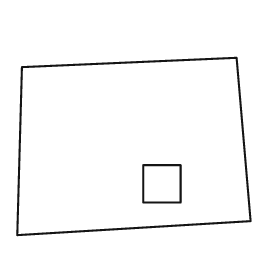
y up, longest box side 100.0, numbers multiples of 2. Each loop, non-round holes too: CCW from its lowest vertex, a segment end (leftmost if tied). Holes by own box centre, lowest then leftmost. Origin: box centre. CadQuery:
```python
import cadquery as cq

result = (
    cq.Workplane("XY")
    .moveTo(-50.0, -38.0)
    .lineTo(50.0, -32.0)
    .lineTo(44.0, 38.0)
    .lineTo(-48.0, 34.0)
    .close()
    .moveTo(4.0, -24.0)
    .lineTo(20.0, -24.0)
    .lineTo(20.0, -8.0)
    .lineTo(4.0, -8.0)
    .close()
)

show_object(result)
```